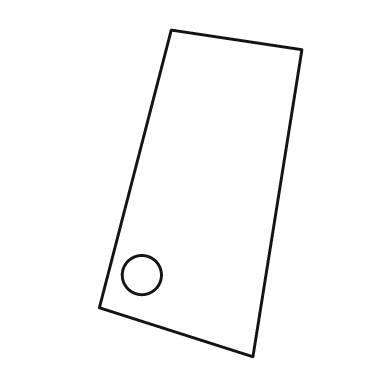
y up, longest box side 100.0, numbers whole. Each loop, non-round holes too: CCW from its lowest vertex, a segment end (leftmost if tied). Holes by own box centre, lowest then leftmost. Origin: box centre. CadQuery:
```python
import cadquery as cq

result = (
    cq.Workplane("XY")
    .moveTo(16.0, -50.0)
    .lineTo(31.0, 44.0)
    .lineTo(-9.0, 50.0)
    .lineTo(-31.0, -35.0)
    .close()
    .moveTo(-18.0, -25.0)
    .circle(6.0)
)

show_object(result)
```